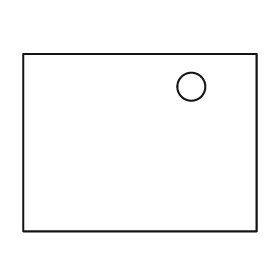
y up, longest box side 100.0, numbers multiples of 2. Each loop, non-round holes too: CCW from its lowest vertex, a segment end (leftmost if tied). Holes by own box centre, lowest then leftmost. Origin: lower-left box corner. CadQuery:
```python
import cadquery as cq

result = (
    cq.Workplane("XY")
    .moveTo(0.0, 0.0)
    .lineTo(100.0, 0.0)
    .lineTo(100.0, 76.0)
    .lineTo(0.0, 76.0)
    .close()
    .moveTo(72.0, 62.0)
    .circle(6.0)
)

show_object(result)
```